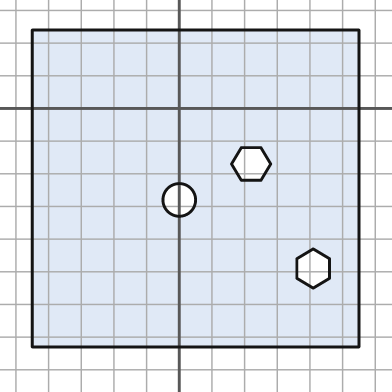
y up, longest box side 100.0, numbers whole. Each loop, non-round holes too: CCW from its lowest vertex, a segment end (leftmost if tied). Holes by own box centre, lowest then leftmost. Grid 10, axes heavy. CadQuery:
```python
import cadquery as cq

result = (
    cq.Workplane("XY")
    .moveTo(-45.0, -73.0)
    .lineTo(55.0, -73.0)
    .lineTo(55.0, 24.0)
    .lineTo(-45.0, 24.0)
    .close()
    .moveTo(41.0, -55.0)
    .lineTo(46.0, -52.0)
    .lineTo(46.0, -46.0)
    .lineTo(41.0, -43.0)
    .lineTo(36.0, -46.0)
    .lineTo(36.0, -52.0)
    .close()
    .moveTo(0.0, -28.0)
    .circle(5.0)
    .moveTo(19.0, -22.0)
    .lineTo(25.0, -22.0)
    .lineTo(28.0, -17.0)
    .lineTo(25.0, -12.0)
    .lineTo(19.0, -12.0)
    .lineTo(16.0, -17.0)
    .close()
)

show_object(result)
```